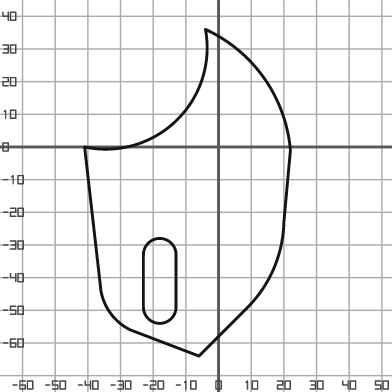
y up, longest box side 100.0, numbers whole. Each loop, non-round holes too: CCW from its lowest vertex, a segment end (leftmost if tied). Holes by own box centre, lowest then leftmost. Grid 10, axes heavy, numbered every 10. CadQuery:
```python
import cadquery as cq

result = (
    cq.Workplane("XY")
    .moveTo(-6.0, -64.0)
    .lineTo(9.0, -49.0)
    .threePointArc((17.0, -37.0), (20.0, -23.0))
    .lineTo(22.0, -1.0)
    .threePointArc((14.0, 21.0), (-4.0, 36.0))
    .threePointArc((-13.0, 8.0), (-41.0, 0.0))
    .lineTo(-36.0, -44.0)
    .threePointArc((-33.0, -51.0), (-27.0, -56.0))
    .close()
    .moveTo(-23.0, -49.0)
    .threePointArc((-18.0, -54.0), (-13.0, -49.0))
    .lineTo(-13.0, -33.0)
    .threePointArc((-18.0, -28.0), (-23.0, -33.0))
    .close()
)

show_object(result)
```